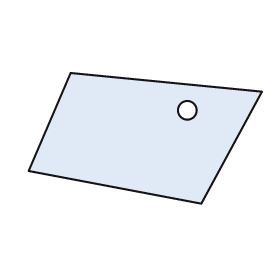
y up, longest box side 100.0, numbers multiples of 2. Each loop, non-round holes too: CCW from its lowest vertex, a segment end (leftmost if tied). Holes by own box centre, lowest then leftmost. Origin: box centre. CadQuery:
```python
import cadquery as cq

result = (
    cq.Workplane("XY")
    .moveTo(24.0, -28.0)
    .lineTo(50.0, 20.0)
    .lineTo(-32.0, 28.0)
    .lineTo(-50.0, -14.0)
    .close()
    .moveTo(18.0, 12.0)
    .circle(4.0)
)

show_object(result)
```